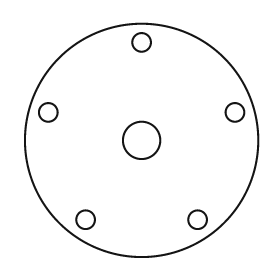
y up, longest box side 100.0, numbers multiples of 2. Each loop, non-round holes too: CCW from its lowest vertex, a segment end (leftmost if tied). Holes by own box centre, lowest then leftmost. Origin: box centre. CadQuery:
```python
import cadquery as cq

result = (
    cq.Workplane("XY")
    .moveTo(0.0, 0.0)
    .circle(50.0)
    .moveTo(-24.0, -34.0)
    .circle(4.0)
    .moveTo(24.0, -34.0)
    .circle(4.0)
    .moveTo(0.0, 0.0)
    .circle(8.0)
    .moveTo(-40.0, 12.0)
    .circle(4.0)
    .moveTo(40.0, 12.0)
    .circle(4.0)
    .moveTo(0.0, 42.0)
    .circle(4.0)
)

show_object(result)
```